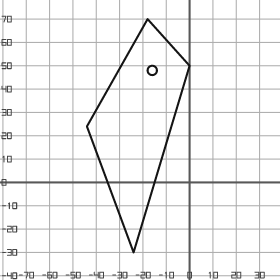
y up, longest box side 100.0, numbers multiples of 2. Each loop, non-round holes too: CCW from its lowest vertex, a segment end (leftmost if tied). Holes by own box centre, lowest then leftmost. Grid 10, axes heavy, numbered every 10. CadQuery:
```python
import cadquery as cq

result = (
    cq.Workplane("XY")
    .moveTo(-24.0, -30.0)
    .lineTo(0.0, 50.0)
    .lineTo(-18.0, 70.0)
    .lineTo(-44.0, 24.0)
    .close()
    .moveTo(-16.0, 48.0)
    .circle(2.0)
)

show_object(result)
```